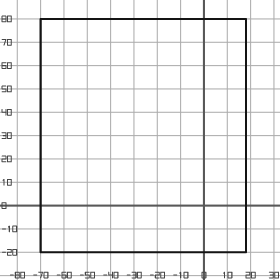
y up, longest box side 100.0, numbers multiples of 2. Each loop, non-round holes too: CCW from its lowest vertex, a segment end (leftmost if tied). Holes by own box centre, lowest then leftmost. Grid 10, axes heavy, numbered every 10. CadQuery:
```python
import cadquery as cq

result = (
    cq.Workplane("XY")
    .moveTo(-70.0, -20.0)
    .lineTo(18.0, -20.0)
    .lineTo(18.0, 80.0)
    .lineTo(-70.0, 80.0)
    .close()
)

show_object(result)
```